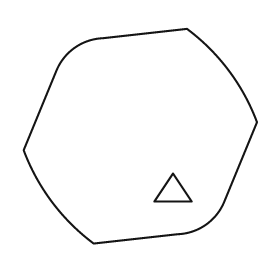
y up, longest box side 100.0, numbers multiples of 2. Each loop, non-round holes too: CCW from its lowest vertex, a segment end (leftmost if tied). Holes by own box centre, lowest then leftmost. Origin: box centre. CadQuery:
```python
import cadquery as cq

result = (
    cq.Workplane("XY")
    .moveTo(-20.0, -46.0)
    .lineTo(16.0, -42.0)
    .threePointArc((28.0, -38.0), (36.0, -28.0))
    .lineTo(50.0, 6.0)
    .threePointArc((38.0, 28.0), (20.0, 46.0))
    .lineTo(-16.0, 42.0)
    .threePointArc((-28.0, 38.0), (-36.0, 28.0))
    .lineTo(-50.0, -6.0)
    .threePointArc((-38.0, -28.0), (-20.0, -46.0))
    .close()
    .moveTo(6.0, -28.0)
    .lineTo(22.0, -28.0)
    .lineTo(14.0, -16.0)
    .close()
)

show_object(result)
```